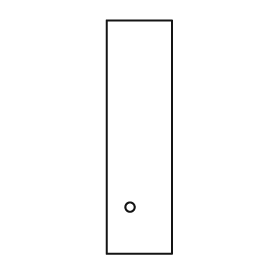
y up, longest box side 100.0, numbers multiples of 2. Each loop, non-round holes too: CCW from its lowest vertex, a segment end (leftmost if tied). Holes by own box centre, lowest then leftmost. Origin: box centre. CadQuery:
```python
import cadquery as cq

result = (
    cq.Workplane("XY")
    .moveTo(-14.0, -50.0)
    .lineTo(14.0, -50.0)
    .lineTo(14.0, 50.0)
    .lineTo(-14.0, 50.0)
    .close()
    .moveTo(-4.0, -30.0)
    .circle(2.0)
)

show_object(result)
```